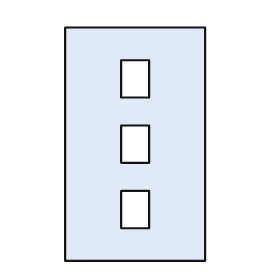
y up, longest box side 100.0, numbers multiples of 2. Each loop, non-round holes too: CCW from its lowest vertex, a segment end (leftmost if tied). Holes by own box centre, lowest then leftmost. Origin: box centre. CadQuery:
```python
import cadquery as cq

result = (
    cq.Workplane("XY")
    .moveTo(-30.0, -50.0)
    .lineTo(30.0, -50.0)
    .lineTo(30.0, 50.0)
    .lineTo(-30.0, 50.0)
    .close()
    .moveTo(-6.0, -36.0)
    .lineTo(6.0, -36.0)
    .lineTo(6.0, -20.0)
    .lineTo(-6.0, -20.0)
    .close()
    .moveTo(-6.0, -8.0)
    .lineTo(6.0, -8.0)
    .lineTo(6.0, 8.0)
    .lineTo(-6.0, 8.0)
    .close()
    .moveTo(-6.0, 20.0)
    .lineTo(6.0, 20.0)
    .lineTo(6.0, 36.0)
    .lineTo(-6.0, 36.0)
    .close()
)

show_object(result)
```